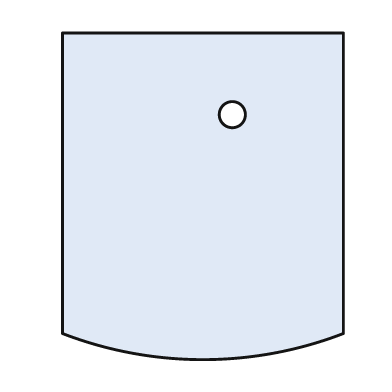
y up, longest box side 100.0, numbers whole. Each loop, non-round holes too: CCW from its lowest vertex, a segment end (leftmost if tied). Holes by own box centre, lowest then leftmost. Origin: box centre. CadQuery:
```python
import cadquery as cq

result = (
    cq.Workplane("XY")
    .moveTo(-43.0, -42.0)
    .threePointArc((0.0, -50.0), (43.0, -42.0))
    .lineTo(43.0, 50.0)
    .lineTo(-43.0, 50.0)
    .close()
    .moveTo(9.0, 25.0)
    .circle(4.0)
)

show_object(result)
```